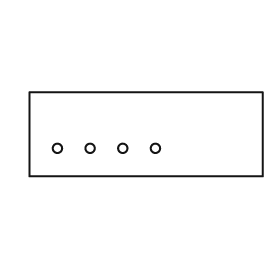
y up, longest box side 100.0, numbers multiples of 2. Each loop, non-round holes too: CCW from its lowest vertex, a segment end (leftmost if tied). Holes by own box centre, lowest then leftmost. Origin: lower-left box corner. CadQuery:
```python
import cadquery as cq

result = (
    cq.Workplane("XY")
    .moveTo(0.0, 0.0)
    .lineTo(100.0, 0.0)
    .lineTo(100.0, 36.0)
    .lineTo(0.0, 36.0)
    .close()
    .moveTo(12.0, 12.0)
    .circle(2.0)
    .moveTo(26.0, 12.0)
    .circle(2.0)
    .moveTo(40.0, 12.0)
    .circle(2.0)
    .moveTo(54.0, 12.0)
    .circle(2.0)
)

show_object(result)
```